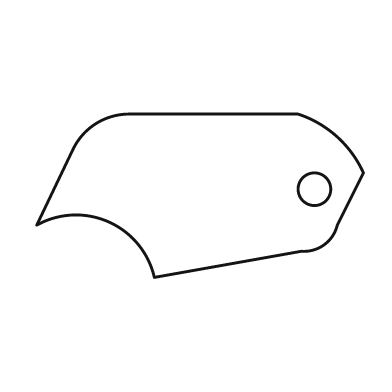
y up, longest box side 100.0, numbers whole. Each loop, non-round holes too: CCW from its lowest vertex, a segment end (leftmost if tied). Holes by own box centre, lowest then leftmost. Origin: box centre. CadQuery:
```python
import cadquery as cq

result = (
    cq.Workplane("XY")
    .moveTo(-14.0, -25.0)
    .lineTo(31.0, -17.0)
    .threePointArc((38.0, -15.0), (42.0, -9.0))
    .lineTo(50.0, 7.0)
    .threePointArc((42.0, 18.0), (30.0, 25.0))
    .lineTo(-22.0, 25.0)
    .threePointArc((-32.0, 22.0), (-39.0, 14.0))
    .lineTo(-50.0, -9.0)
    .threePointArc((-28.0, -8.0), (-14.0, -25.0))
    .close()
    .moveTo(35.0, 2.0)
    .circle(5.0)
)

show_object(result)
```